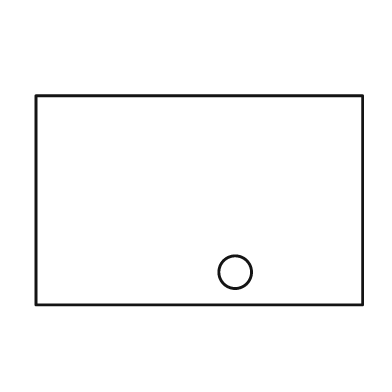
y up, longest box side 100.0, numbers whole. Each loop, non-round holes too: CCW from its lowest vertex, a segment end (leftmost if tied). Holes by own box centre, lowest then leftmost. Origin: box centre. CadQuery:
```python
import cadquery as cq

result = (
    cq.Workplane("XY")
    .moveTo(-50.0, -32.0)
    .lineTo(50.0, -32.0)
    .lineTo(50.0, 32.0)
    .lineTo(-50.0, 32.0)
    .close()
    .moveTo(11.0, -22.0)
    .circle(5.0)
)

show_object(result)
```